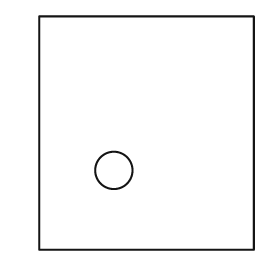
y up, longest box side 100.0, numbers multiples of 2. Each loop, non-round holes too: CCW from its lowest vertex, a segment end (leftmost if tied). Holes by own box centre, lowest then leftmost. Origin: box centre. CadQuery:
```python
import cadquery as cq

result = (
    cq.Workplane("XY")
    .moveTo(-46.0, -50.0)
    .lineTo(46.0, -50.0)
    .lineTo(46.0, 50.0)
    .lineTo(-46.0, 50.0)
    .close()
    .moveTo(-14.0, -16.0)
    .circle(8.0)
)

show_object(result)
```